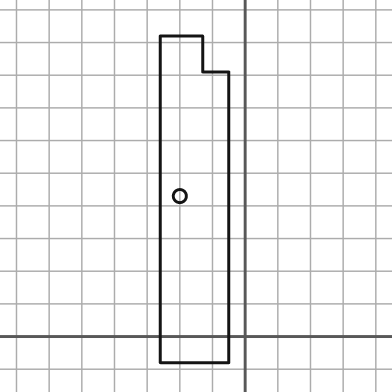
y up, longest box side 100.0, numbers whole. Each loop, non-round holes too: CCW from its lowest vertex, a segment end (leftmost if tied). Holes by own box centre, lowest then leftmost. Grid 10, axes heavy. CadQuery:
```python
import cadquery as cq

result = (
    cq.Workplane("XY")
    .moveTo(-26.0, -8.0)
    .lineTo(-5.0, -8.0)
    .lineTo(-5.0, 81.0)
    .lineTo(-13.0, 81.0)
    .lineTo(-13.0, 92.0)
    .lineTo(-26.0, 92.0)
    .close()
    .moveTo(-20.0, 43.0)
    .circle(2.0)
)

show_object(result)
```